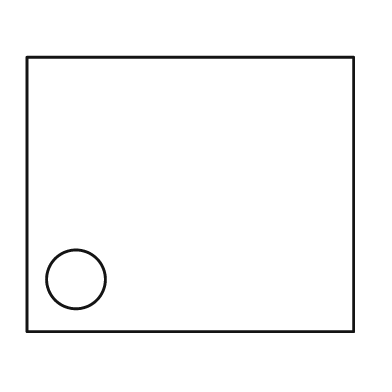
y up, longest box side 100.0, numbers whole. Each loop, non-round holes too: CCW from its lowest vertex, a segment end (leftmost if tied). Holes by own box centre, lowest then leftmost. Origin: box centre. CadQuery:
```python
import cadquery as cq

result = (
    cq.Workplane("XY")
    .moveTo(-50.0, -42.0)
    .lineTo(50.0, -42.0)
    .lineTo(50.0, 42.0)
    .lineTo(-50.0, 42.0)
    .close()
    .moveTo(-35.0, -26.0)
    .circle(9.0)
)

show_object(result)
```